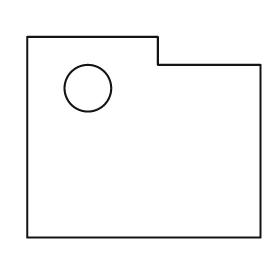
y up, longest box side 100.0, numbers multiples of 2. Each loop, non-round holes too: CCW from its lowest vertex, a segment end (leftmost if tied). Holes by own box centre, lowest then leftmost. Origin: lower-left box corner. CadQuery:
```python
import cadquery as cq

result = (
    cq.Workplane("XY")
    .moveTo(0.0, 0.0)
    .lineTo(100.0, 0.0)
    .lineTo(100.0, 74.0)
    .lineTo(56.0, 74.0)
    .lineTo(56.0, 86.0)
    .lineTo(0.0, 86.0)
    .close()
    .moveTo(26.0, 64.0)
    .circle(10.0)
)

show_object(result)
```